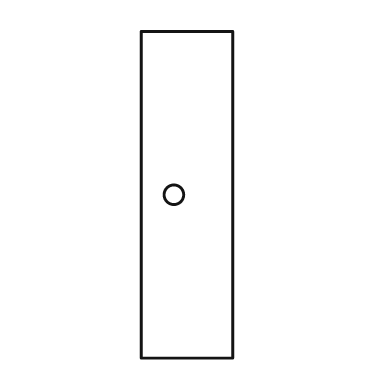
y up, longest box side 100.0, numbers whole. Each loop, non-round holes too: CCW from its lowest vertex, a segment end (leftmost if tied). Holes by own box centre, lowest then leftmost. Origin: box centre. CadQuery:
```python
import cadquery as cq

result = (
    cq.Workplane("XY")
    .moveTo(-14.0, -50.0)
    .lineTo(14.0, -50.0)
    .lineTo(14.0, 50.0)
    .lineTo(-14.0, 50.0)
    .close()
    .moveTo(-4.0, 0.0)
    .circle(3.0)
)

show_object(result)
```